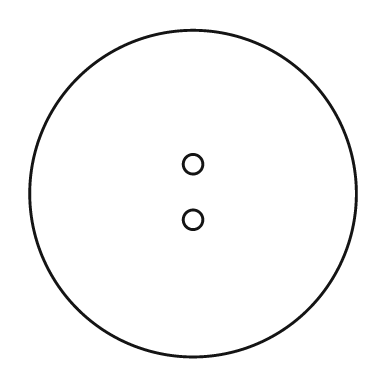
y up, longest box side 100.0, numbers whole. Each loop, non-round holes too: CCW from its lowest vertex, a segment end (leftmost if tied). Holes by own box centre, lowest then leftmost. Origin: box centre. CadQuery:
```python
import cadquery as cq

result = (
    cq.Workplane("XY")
    .moveTo(0.0, 0.0)
    .circle(50.0)
    .moveTo(0.0, -8.0)
    .circle(3.0)
    .moveTo(0.0, 9.0)
    .circle(3.0)
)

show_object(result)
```